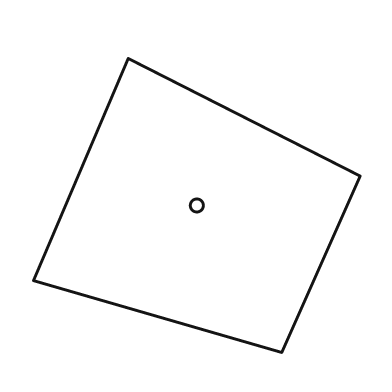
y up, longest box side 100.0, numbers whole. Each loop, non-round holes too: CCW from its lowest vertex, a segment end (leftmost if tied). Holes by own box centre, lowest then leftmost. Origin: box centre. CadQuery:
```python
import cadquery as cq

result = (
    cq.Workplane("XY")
    .moveTo(26.0, -45.0)
    .lineTo(50.0, 9.0)
    .lineTo(-21.0, 45.0)
    .lineTo(-50.0, -23.0)
    .close()
    .moveTo(0.0, 0.0)
    .circle(2.0)
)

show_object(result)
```